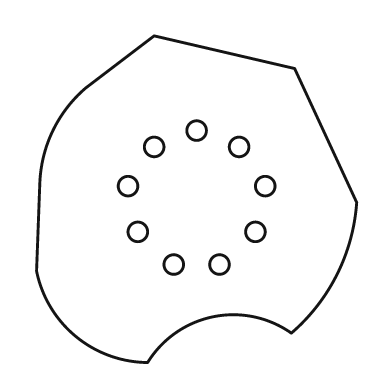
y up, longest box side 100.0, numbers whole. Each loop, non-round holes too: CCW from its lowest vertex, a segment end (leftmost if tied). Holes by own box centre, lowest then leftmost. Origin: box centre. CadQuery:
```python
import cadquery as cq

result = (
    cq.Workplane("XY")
    .moveTo(-15.0, -50.0)
    .threePointArc((5.0, -36.0), (29.0, -41.0))
    .threePointArc((43.0, -23.0), (49.0, -1.0))
    .lineTo(30.0, 40.0)
    .lineTo(-13.0, 50.0)
    .lineTo(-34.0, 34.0)
    .threePointArc((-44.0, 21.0), (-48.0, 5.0))
    .lineTo(-49.0, -22.0)
    .threePointArc((-37.0, -42.0), (-15.0, -50.0))
    .close()
    .moveTo(-7.0, -20.0)
    .circle(3.0)
    .moveTo(7.0, -20.0)
    .circle(3.0)
    .moveTo(-18.0, -10.0)
    .circle(3.0)
    .moveTo(18.0, -10.0)
    .circle(3.0)
    .moveTo(-21.0, 4.0)
    .circle(3.0)
    .moveTo(21.0, 4.0)
    .circle(3.0)
    .moveTo(-13.0, 16.0)
    .circle(3.0)
    .moveTo(13.0, 16.0)
    .circle(3.0)
    .moveTo(0.0, 21.0)
    .circle(3.0)
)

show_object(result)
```